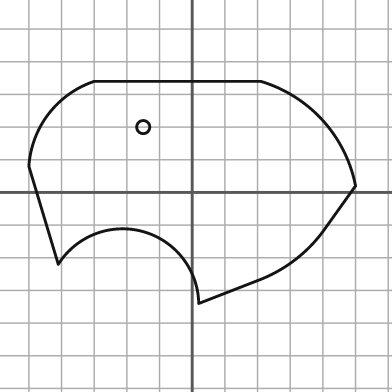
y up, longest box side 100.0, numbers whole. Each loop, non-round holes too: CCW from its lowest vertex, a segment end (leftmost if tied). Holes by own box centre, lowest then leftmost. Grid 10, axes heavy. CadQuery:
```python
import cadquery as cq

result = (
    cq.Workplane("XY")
    .moveTo(2.0, -34.0)
    .lineTo(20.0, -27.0)
    .threePointArc((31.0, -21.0), (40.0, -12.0))
    .lineTo(50.0, 2.0)
    .threePointArc((40.0, 22.0), (21.0, 34.0))
    .lineTo(-30.0, 34.0)
    .threePointArc((-44.0, 24.0), (-50.0, 8.0))
    .lineTo(-41.0, -22.0)
    .threePointArc((-15.0, -12.0), (2.0, -34.0))
    .close()
    .moveTo(-15.0, 20.0)
    .circle(2.0)
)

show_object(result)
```